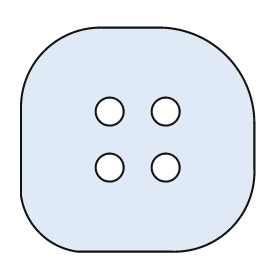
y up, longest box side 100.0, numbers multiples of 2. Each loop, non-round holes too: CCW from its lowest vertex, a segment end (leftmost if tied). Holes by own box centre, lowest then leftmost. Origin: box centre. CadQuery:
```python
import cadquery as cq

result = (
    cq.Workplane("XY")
    .moveTo(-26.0, -48.0)
    .lineTo(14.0, -48.0)
    .threePointArc((40.0, -38.0), (50.0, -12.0))
    .lineTo(50.0, 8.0)
    .threePointArc((38.0, 36.0), (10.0, 48.0))
    .lineTo(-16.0, 48.0)
    .threePointArc((-40.0, 38.0), (-50.0, 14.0))
    .lineTo(-50.0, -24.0)
    .threePointArc((-42.0, -40.0), (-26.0, -48.0))
    .close()
    .moveTo(-12.0, -12.0)
    .circle(6.0)
    .moveTo(12.0, -12.0)
    .circle(6.0)
    .moveTo(-12.0, 12.0)
    .circle(6.0)
    .moveTo(12.0, 12.0)
    .circle(6.0)
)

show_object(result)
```